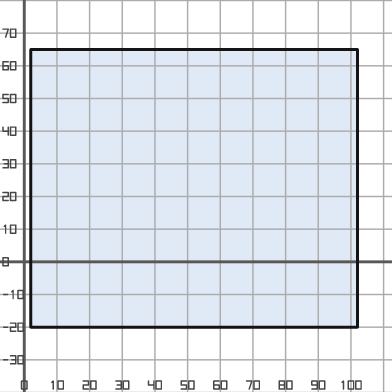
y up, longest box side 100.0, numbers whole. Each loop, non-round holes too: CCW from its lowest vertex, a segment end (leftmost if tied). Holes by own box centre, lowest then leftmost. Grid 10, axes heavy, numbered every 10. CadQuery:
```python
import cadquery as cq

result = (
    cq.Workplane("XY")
    .moveTo(2.0, -20.0)
    .lineTo(102.0, -20.0)
    .lineTo(102.0, 65.0)
    .lineTo(2.0, 65.0)
    .close()
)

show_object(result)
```